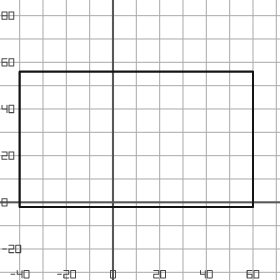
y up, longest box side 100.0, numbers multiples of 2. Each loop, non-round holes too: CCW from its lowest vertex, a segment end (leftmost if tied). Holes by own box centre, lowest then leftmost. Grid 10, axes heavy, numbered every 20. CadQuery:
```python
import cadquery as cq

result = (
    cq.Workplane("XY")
    .moveTo(-40.0, -2.0)
    .lineTo(60.0, -2.0)
    .lineTo(60.0, 56.0)
    .lineTo(-40.0, 56.0)
    .close()
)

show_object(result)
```